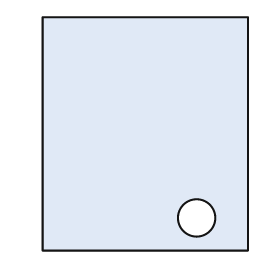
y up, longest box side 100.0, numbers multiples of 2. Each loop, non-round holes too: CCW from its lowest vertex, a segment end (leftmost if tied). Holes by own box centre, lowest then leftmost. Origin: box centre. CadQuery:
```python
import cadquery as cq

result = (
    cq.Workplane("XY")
    .moveTo(-44.0, -50.0)
    .lineTo(44.0, -50.0)
    .lineTo(44.0, 50.0)
    .lineTo(-44.0, 50.0)
    .close()
    .moveTo(22.0, -36.0)
    .circle(8.0)
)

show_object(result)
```